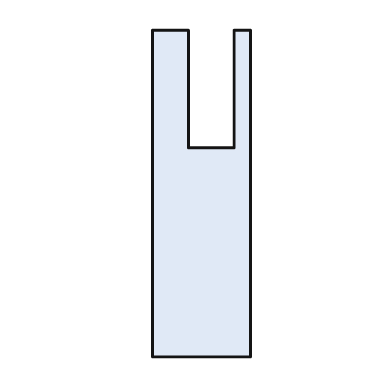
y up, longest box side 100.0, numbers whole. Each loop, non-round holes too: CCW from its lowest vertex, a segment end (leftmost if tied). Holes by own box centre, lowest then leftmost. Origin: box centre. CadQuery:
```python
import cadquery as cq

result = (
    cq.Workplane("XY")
    .moveTo(-15.0, -50.0)
    .lineTo(15.0, -50.0)
    .lineTo(15.0, 50.0)
    .lineTo(10.0, 50.0)
    .lineTo(10.0, 14.0)
    .lineTo(-4.0, 14.0)
    .lineTo(-4.0, 50.0)
    .lineTo(-15.0, 50.0)
    .close()
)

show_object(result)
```